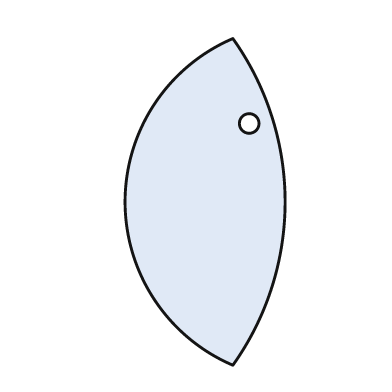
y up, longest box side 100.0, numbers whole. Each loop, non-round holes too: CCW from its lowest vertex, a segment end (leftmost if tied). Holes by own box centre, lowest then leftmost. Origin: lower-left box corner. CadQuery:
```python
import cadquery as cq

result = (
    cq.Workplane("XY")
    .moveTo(33.0, 0.0)
    .threePointArc((49.0, 50.0), (33.0, 100.0))
    .threePointArc((0.0, 50.0), (33.0, 0.0))
    .close()
    .moveTo(38.0, 74.0)
    .circle(3.0)
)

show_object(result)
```